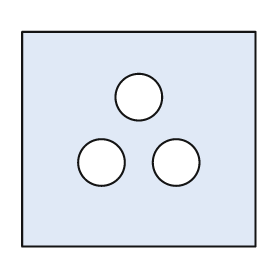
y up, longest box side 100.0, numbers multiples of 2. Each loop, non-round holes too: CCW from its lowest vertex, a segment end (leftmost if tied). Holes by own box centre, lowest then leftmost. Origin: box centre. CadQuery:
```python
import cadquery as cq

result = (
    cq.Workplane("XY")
    .moveTo(-50.0, -46.0)
    .lineTo(50.0, -46.0)
    .lineTo(50.0, 46.0)
    .lineTo(-50.0, 46.0)
    .close()
    .moveTo(-16.0, -10.0)
    .circle(10.0)
    .moveTo(16.0, -10.0)
    .circle(10.0)
    .moveTo(0.0, 18.0)
    .circle(10.0)
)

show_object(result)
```